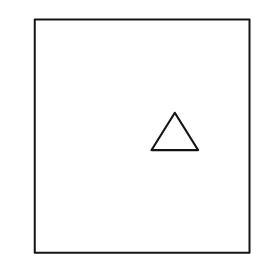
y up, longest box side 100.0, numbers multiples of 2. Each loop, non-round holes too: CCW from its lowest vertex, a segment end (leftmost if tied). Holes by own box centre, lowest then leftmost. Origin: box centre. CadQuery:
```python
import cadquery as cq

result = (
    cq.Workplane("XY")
    .moveTo(-46.0, -50.0)
    .lineTo(46.0, -50.0)
    .lineTo(46.0, 50.0)
    .lineTo(-46.0, 50.0)
    .close()
    .moveTo(4.0, -6.0)
    .lineTo(24.0, -6.0)
    .lineTo(14.0, 10.0)
    .close()
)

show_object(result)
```